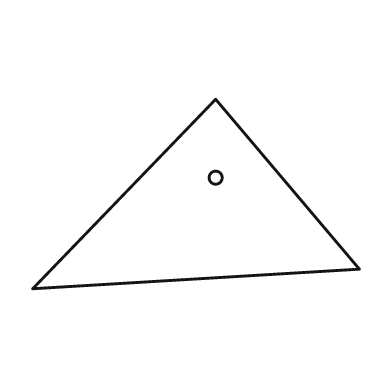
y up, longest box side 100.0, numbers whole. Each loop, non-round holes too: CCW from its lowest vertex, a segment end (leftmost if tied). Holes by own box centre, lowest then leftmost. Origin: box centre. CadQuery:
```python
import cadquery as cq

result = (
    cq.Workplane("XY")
    .moveTo(-50.0, -29.0)
    .lineTo(50.0, -23.0)
    .lineTo(6.0, 29.0)
    .close()
    .moveTo(6.0, 5.0)
    .circle(2.0)
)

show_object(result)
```